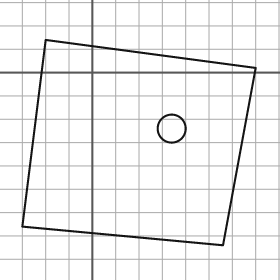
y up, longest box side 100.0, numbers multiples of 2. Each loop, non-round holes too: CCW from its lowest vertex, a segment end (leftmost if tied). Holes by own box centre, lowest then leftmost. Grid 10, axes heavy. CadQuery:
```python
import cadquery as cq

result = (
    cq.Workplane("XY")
    .moveTo(56.0, -74.0)
    .lineTo(70.0, 2.0)
    .lineTo(-20.0, 14.0)
    .lineTo(-30.0, -66.0)
    .close()
    .moveTo(34.0, -24.0)
    .circle(6.0)
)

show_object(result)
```